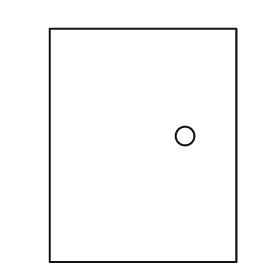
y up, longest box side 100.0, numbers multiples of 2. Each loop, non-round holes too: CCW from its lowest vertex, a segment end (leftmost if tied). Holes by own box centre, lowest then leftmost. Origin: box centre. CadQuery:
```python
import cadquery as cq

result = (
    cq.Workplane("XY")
    .moveTo(-40.0, -50.0)
    .lineTo(40.0, -50.0)
    .lineTo(40.0, 50.0)
    .lineTo(-40.0, 50.0)
    .close()
    .moveTo(18.0, 4.0)
    .circle(4.0)
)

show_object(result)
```